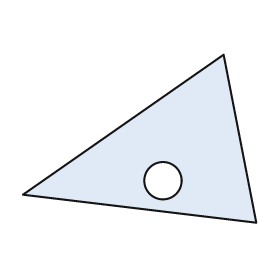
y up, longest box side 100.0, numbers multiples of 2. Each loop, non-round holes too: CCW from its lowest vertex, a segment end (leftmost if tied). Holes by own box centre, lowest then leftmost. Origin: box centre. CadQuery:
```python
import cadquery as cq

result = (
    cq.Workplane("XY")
    .moveTo(50.0, -36.0)
    .lineTo(36.0, 36.0)
    .lineTo(-50.0, -24.0)
    .close()
    .moveTo(10.0, -18.0)
    .circle(8.0)
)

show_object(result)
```